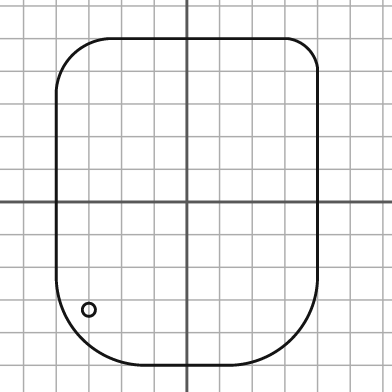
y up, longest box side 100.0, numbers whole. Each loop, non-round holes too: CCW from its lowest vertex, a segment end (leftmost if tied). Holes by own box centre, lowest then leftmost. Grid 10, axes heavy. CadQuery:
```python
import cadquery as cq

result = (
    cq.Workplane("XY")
    .moveTo(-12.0, -50.0)
    .lineTo(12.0, -50.0)
    .threePointArc((32.0, -42.0), (40.0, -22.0))
    .lineTo(40.0, 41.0)
    .threePointArc((37.0, 47.0), (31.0, 50.0))
    .lineTo(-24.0, 50.0)
    .threePointArc((-35.0, 45.0), (-40.0, 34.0))
    .lineTo(-40.0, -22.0)
    .threePointArc((-32.0, -42.0), (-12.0, -50.0))
    .close()
    .moveTo(-30.0, -33.0)
    .circle(2.0)
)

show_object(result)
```